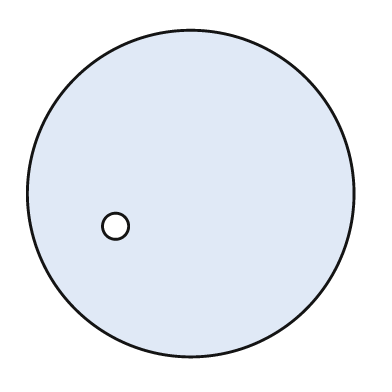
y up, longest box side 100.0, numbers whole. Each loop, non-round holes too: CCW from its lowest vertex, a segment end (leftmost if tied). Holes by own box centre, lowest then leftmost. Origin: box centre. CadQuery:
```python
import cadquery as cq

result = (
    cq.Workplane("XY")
    .moveTo(0.0, 0.0)
    .circle(50.0)
    .moveTo(-23.0, -10.0)
    .circle(4.0)
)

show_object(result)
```